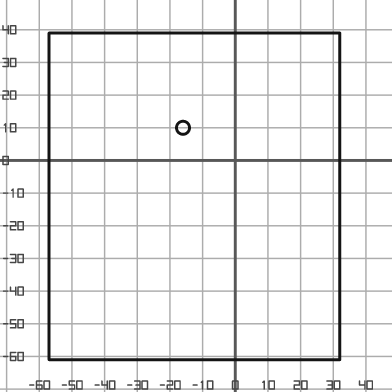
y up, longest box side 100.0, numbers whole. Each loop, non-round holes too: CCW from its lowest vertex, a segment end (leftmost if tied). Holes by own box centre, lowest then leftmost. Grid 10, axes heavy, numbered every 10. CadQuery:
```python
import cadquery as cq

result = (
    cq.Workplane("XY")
    .moveTo(-57.0, -61.0)
    .lineTo(32.0, -61.0)
    .lineTo(32.0, 39.0)
    .lineTo(-57.0, 39.0)
    .close()
    .moveTo(-16.0, 10.0)
    .circle(2.0)
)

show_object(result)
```